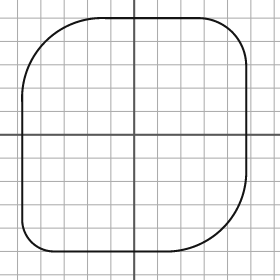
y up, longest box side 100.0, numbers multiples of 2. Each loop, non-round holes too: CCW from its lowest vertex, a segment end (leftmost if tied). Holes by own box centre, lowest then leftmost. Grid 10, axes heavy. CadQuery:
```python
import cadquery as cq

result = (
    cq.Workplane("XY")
    .moveTo(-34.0, -50.0)
    .lineTo(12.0, -50.0)
    .threePointArc((38.0, -40.0), (48.0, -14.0))
    .lineTo(48.0, 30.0)
    .threePointArc((42.0, 44.0), (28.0, 50.0))
    .lineTo(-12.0, 50.0)
    .threePointArc((-38.0, 40.0), (-48.0, 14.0))
    .lineTo(-48.0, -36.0)
    .threePointArc((-44.0, -46.0), (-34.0, -50.0))
    .close()
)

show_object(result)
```